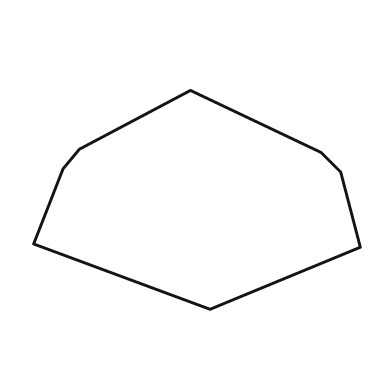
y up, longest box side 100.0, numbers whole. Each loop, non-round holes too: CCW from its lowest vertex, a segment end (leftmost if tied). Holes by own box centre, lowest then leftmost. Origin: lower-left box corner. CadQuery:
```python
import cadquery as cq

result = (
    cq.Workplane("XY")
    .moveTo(54.0, 0.0)
    .lineTo(100.0, 19.0)
    .lineTo(94.0, 42.0)
    .lineTo(88.0, 48.0)
    .lineTo(48.0, 67.0)
    .lineTo(14.0, 49.0)
    .lineTo(9.0, 43.0)
    .lineTo(0.0, 20.0)
    .close()
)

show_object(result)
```